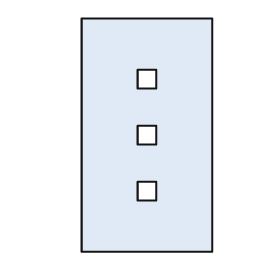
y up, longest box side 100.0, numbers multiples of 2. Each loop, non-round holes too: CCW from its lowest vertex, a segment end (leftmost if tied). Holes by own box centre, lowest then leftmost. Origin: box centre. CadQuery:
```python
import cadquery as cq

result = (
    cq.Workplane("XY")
    .moveTo(-28.0, -50.0)
    .lineTo(28.0, -50.0)
    .lineTo(28.0, 50.0)
    .lineTo(-28.0, 50.0)
    .close()
    .moveTo(-4.0, -28.0)
    .lineTo(4.0, -28.0)
    .lineTo(4.0, -20.0)
    .lineTo(-4.0, -20.0)
    .close()
    .moveTo(-4.0, -4.0)
    .lineTo(4.0, -4.0)
    .lineTo(4.0, 4.0)
    .lineTo(-4.0, 4.0)
    .close()
    .moveTo(-4.0, 20.0)
    .lineTo(4.0, 20.0)
    .lineTo(4.0, 28.0)
    .lineTo(-4.0, 28.0)
    .close()
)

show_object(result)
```